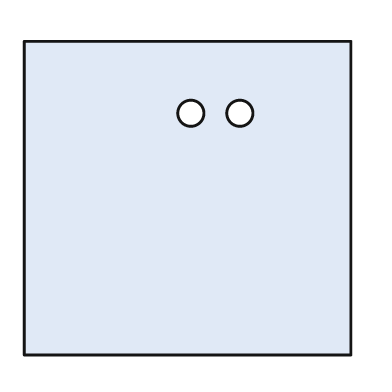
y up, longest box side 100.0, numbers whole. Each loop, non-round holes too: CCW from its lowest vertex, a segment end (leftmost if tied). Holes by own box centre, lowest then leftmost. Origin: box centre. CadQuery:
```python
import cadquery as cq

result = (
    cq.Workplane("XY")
    .moveTo(-50.0, -48.0)
    .lineTo(50.0, -48.0)
    .lineTo(50.0, 48.0)
    .lineTo(-50.0, 48.0)
    .close()
    .moveTo(1.0, 26.0)
    .circle(4.0)
    .moveTo(16.0, 26.0)
    .circle(4.0)
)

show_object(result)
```